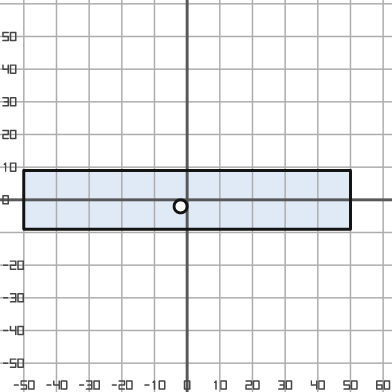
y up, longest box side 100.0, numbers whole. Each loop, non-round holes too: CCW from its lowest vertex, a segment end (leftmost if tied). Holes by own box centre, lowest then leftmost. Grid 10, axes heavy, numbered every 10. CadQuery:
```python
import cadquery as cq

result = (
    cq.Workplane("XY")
    .moveTo(-50.0, -9.0)
    .lineTo(50.0, -9.0)
    .lineTo(50.0, 9.0)
    .lineTo(-50.0, 9.0)
    .close()
    .moveTo(-2.0, -2.0)
    .circle(2.0)
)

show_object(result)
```